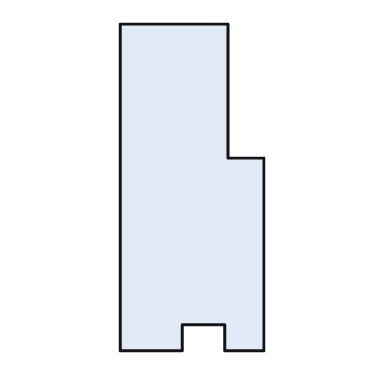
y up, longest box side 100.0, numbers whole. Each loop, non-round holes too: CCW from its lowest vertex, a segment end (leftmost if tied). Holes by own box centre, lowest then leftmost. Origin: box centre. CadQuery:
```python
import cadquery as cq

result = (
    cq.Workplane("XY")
    .moveTo(-22.0, -50.0)
    .lineTo(-3.0, -50.0)
    .lineTo(-3.0, -42.0)
    .lineTo(10.0, -42.0)
    .lineTo(10.0, -50.0)
    .lineTo(22.0, -50.0)
    .lineTo(22.0, 9.0)
    .lineTo(11.0, 9.0)
    .lineTo(11.0, 50.0)
    .lineTo(-22.0, 50.0)
    .close()
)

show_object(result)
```